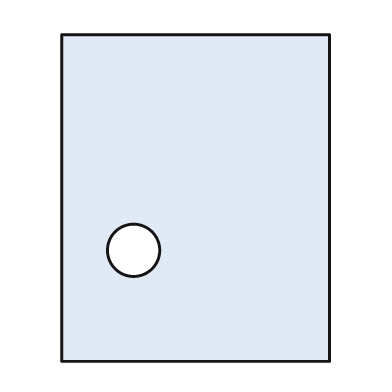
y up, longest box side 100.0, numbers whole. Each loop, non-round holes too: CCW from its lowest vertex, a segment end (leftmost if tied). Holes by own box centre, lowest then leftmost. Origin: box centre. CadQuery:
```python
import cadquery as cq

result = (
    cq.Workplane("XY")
    .moveTo(-41.0, -50.0)
    .lineTo(41.0, -50.0)
    .lineTo(41.0, 50.0)
    .lineTo(-41.0, 50.0)
    .close()
    .moveTo(-19.0, -16.0)
    .circle(8.0)
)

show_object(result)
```